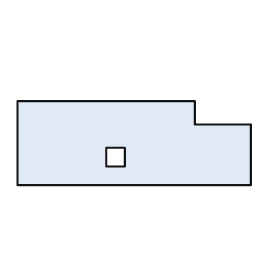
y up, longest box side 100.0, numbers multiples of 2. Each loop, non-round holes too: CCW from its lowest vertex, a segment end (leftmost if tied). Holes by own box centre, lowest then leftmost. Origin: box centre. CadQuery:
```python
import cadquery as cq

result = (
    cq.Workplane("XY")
    .moveTo(-50.0, -18.0)
    .lineTo(50.0, -18.0)
    .lineTo(50.0, 8.0)
    .lineTo(26.0, 8.0)
    .lineTo(26.0, 18.0)
    .lineTo(-50.0, 18.0)
    .close()
    .moveTo(-12.0, -10.0)
    .lineTo(-4.0, -10.0)
    .lineTo(-4.0, -2.0)
    .lineTo(-12.0, -2.0)
    .close()
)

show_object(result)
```